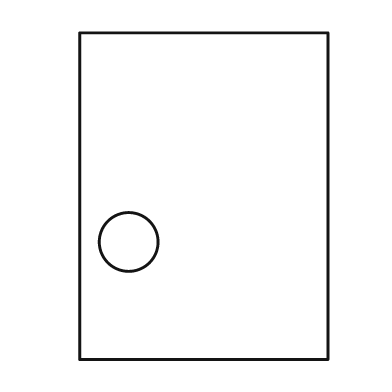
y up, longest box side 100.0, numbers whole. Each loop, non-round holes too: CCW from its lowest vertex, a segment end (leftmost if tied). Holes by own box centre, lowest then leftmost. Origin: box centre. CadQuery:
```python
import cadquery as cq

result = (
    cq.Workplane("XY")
    .moveTo(-38.0, -50.0)
    .lineTo(38.0, -50.0)
    .lineTo(38.0, 50.0)
    .lineTo(-38.0, 50.0)
    .close()
    .moveTo(-23.0, -14.0)
    .circle(9.0)
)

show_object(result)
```